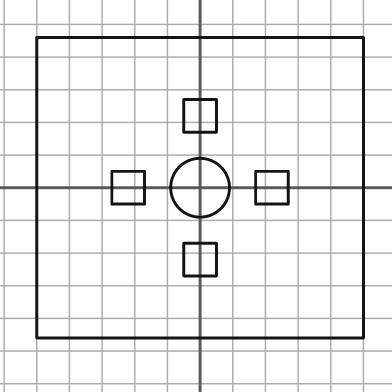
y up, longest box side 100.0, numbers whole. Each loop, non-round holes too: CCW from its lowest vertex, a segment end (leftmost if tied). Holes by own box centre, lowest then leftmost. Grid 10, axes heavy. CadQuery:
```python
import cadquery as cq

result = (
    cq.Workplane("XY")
    .moveTo(-50.0, -46.0)
    .lineTo(50.0, -46.0)
    .lineTo(50.0, 46.0)
    .lineTo(-50.0, 46.0)
    .close()
    .moveTo(-5.0, -27.0)
    .lineTo(5.0, -27.0)
    .lineTo(5.0, -17.0)
    .lineTo(-5.0, -17.0)
    .close()
    .moveTo(-27.0, -5.0)
    .lineTo(-17.0, -5.0)
    .lineTo(-17.0, 5.0)
    .lineTo(-27.0, 5.0)
    .close()
    .moveTo(0.0, 0.0)
    .circle(9.0)
    .moveTo(17.0, -5.0)
    .lineTo(27.0, -5.0)
    .lineTo(27.0, 5.0)
    .lineTo(17.0, 5.0)
    .close()
    .moveTo(-5.0, 17.0)
    .lineTo(5.0, 17.0)
    .lineTo(5.0, 27.0)
    .lineTo(-5.0, 27.0)
    .close()
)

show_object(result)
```